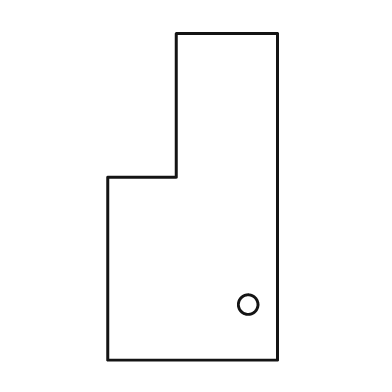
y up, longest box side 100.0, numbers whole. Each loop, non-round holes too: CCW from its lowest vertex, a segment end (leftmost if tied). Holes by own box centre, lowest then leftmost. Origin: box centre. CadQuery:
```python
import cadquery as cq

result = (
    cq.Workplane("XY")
    .moveTo(-26.0, -50.0)
    .lineTo(26.0, -50.0)
    .lineTo(26.0, 50.0)
    .lineTo(-5.0, 50.0)
    .lineTo(-5.0, 6.0)
    .lineTo(-26.0, 6.0)
    .close()
    .moveTo(17.0, -33.0)
    .circle(3.0)
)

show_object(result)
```